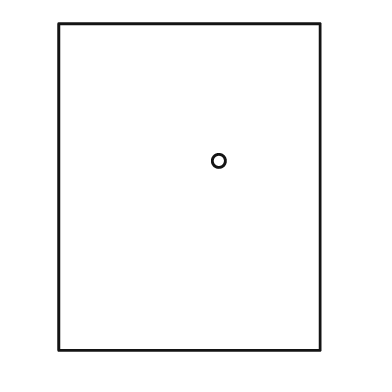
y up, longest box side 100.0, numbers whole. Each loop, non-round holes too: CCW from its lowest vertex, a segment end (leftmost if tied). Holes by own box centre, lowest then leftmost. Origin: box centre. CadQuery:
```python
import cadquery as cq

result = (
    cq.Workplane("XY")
    .moveTo(-40.0, -50.0)
    .lineTo(40.0, -50.0)
    .lineTo(40.0, 50.0)
    .lineTo(-40.0, 50.0)
    .close()
    .moveTo(9.0, 8.0)
    .circle(2.0)
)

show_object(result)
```